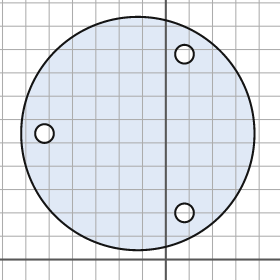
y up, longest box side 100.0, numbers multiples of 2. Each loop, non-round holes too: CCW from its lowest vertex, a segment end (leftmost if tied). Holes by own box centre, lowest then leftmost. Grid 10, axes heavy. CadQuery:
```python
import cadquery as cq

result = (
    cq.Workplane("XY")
    .moveTo(-12.0, 54.0)
    .circle(50.0)
    .moveTo(8.0, 20.0)
    .circle(4.0)
    .moveTo(-52.0, 54.0)
    .circle(4.0)
    .moveTo(8.0, 88.0)
    .circle(4.0)
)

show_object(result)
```